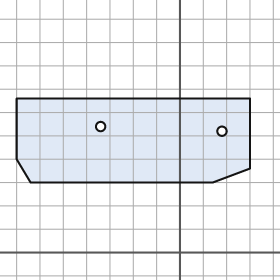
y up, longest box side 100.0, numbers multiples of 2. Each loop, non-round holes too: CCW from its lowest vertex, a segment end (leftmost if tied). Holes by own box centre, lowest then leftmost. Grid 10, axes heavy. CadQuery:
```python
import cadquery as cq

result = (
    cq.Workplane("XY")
    .moveTo(-64.0, 30.0)
    .lineTo(14.0, 30.0)
    .lineTo(30.0, 36.0)
    .lineTo(30.0, 66.0)
    .lineTo(-70.0, 66.0)
    .lineTo(-70.0, 40.0)
    .close()
    .moveTo(18.0, 52.0)
    .circle(2.0)
    .moveTo(-34.0, 54.0)
    .circle(2.0)
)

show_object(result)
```